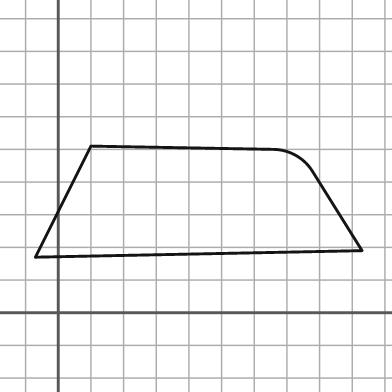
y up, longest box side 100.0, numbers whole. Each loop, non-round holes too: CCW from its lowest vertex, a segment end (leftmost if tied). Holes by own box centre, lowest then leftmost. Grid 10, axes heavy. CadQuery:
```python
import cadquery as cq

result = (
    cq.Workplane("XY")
    .moveTo(-7.0, 17.0)
    .lineTo(93.0, 19.0)
    .lineTo(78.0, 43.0)
    .threePointArc((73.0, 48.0), (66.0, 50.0))
    .lineTo(10.0, 51.0)
    .close()
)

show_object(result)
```